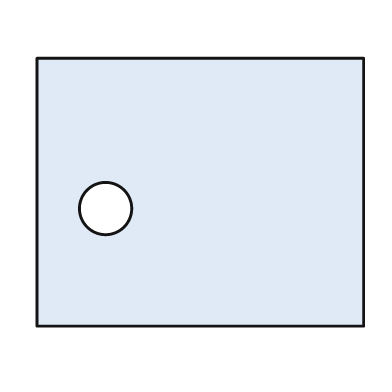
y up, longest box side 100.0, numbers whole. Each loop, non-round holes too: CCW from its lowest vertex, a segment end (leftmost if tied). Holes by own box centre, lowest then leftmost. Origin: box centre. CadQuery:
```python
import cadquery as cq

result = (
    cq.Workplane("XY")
    .moveTo(-50.0, -41.0)
    .lineTo(50.0, -41.0)
    .lineTo(50.0, 41.0)
    .lineTo(-50.0, 41.0)
    .close()
    .moveTo(-29.0, -5.0)
    .circle(8.0)
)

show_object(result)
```